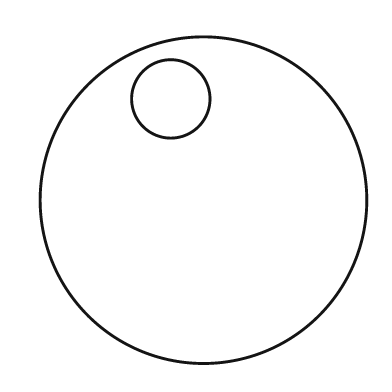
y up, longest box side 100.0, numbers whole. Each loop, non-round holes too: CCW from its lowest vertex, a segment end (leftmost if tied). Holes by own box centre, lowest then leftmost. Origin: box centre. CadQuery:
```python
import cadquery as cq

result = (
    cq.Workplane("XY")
    .moveTo(0.0, 0.0)
    .circle(50.0)
    .moveTo(-10.0, 31.0)
    .circle(12.0)
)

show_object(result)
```